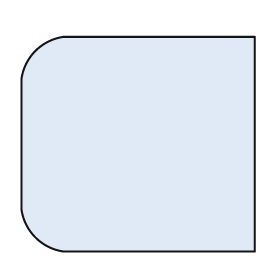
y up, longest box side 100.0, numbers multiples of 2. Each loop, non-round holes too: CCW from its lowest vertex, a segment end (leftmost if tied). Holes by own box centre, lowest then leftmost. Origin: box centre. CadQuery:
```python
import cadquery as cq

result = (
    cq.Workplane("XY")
    .moveTo(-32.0, -46.0)
    .lineTo(50.0, -46.0)
    .lineTo(50.0, 46.0)
    .lineTo(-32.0, 46.0)
    .threePointArc((-44.0, 40.0), (-50.0, 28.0))
    .lineTo(-50.0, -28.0)
    .threePointArc((-44.0, -40.0), (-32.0, -46.0))
    .close()
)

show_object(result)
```